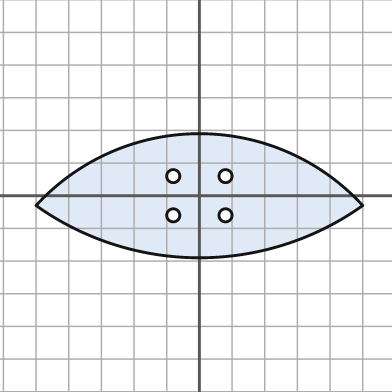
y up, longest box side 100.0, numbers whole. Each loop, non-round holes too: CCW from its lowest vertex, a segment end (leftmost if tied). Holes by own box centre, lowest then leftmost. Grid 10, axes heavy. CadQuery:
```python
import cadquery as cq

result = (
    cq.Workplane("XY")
    .moveTo(-50.0, -3.0)
    .threePointArc((0.0, -19.0), (50.0, -3.0))
    .threePointArc((0.0, 19.0), (-50.0, -3.0))
    .close()
    .moveTo(-8.0, -6.0)
    .circle(2.0)
    .moveTo(8.0, -6.0)
    .circle(2.0)
    .moveTo(-8.0, 6.0)
    .circle(2.0)
    .moveTo(8.0, 6.0)
    .circle(2.0)
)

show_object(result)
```